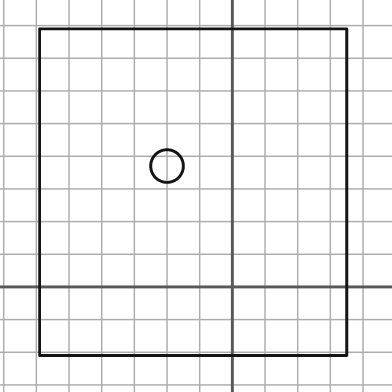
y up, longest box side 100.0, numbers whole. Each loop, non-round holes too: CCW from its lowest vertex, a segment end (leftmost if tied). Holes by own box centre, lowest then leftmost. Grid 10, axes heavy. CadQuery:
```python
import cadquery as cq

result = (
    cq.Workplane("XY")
    .moveTo(-59.0, -21.0)
    .lineTo(35.0, -21.0)
    .lineTo(35.0, 79.0)
    .lineTo(-59.0, 79.0)
    .close()
    .moveTo(-20.0, 37.0)
    .circle(5.0)
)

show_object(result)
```